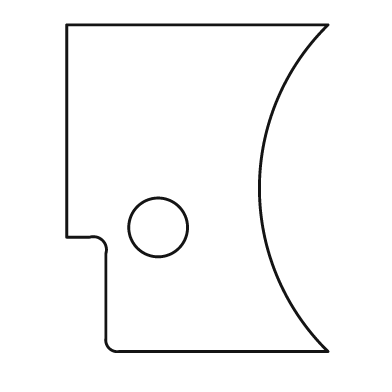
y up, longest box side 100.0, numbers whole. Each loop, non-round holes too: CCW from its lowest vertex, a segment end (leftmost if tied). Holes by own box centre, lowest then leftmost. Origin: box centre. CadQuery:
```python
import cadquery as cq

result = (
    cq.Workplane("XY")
    .moveTo(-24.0, -50.0)
    .lineTo(40.0, -50.0)
    .threePointArc((19.0, 0.0), (40.0, 50.0))
    .lineTo(-40.0, 50.0)
    .lineTo(-40.0, -15.0)
    .lineTo(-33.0, -15.0)
    .threePointArc((-29.0, -16.0), (-28.0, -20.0))
    .lineTo(-28.0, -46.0)
    .threePointArc((-27.0, -49.0), (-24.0, -50.0))
    .close()
    .moveTo(-12.0, -12.0)
    .circle(9.0)
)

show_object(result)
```